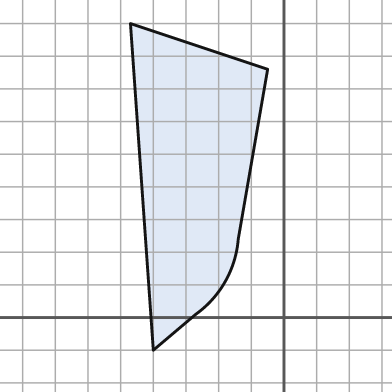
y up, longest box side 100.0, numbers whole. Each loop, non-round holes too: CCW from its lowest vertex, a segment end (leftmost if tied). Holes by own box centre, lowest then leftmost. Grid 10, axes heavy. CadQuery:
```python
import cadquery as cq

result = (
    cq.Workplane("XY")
    .moveTo(-40.0, -10.0)
    .lineTo(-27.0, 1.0)
    .threePointArc((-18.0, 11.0), (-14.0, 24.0))
    .lineTo(-5.0, 76.0)
    .lineTo(-47.0, 90.0)
    .close()
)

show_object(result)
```